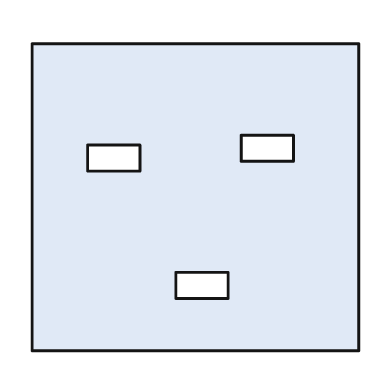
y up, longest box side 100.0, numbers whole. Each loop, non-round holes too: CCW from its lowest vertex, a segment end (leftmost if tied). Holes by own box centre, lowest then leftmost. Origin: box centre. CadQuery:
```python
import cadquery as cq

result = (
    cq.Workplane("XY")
    .moveTo(-50.0, -47.0)
    .lineTo(50.0, -47.0)
    .lineTo(50.0, 47.0)
    .lineTo(-50.0, 47.0)
    .close()
    .moveTo(-6.0, -31.0)
    .lineTo(10.0, -31.0)
    .lineTo(10.0, -23.0)
    .lineTo(-6.0, -23.0)
    .close()
    .moveTo(-33.0, 8.0)
    .lineTo(-17.0, 8.0)
    .lineTo(-17.0, 16.0)
    .lineTo(-33.0, 16.0)
    .close()
    .moveTo(14.0, 11.0)
    .lineTo(30.0, 11.0)
    .lineTo(30.0, 19.0)
    .lineTo(14.0, 19.0)
    .close()
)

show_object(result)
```